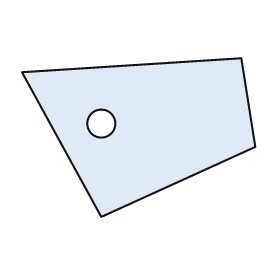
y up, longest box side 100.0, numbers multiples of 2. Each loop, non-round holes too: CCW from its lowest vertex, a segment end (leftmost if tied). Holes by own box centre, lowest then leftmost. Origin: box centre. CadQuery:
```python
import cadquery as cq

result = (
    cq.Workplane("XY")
    .moveTo(-16.0, -34.0)
    .lineTo(50.0, -4.0)
    .lineTo(44.0, 34.0)
    .lineTo(-50.0, 28.0)
    .close()
    .moveTo(-16.0, 6.0)
    .circle(6.0)
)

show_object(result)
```